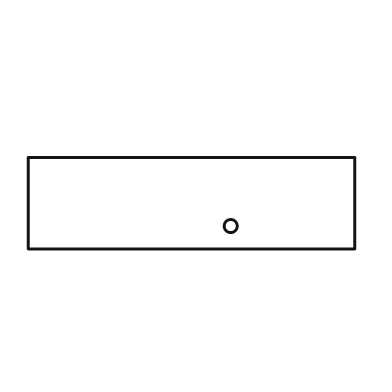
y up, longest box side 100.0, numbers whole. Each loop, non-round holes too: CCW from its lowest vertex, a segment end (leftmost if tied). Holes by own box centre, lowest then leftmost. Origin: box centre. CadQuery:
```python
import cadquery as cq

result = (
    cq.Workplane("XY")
    .moveTo(-50.0, -14.0)
    .lineTo(50.0, -14.0)
    .lineTo(50.0, 14.0)
    .lineTo(-50.0, 14.0)
    .close()
    .moveTo(12.0, -7.0)
    .circle(2.0)
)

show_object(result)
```